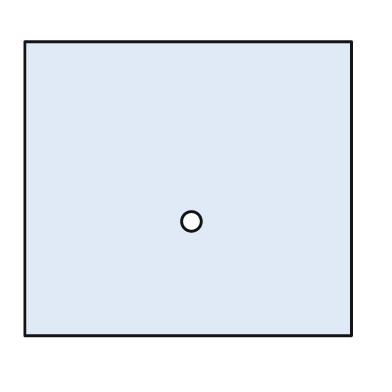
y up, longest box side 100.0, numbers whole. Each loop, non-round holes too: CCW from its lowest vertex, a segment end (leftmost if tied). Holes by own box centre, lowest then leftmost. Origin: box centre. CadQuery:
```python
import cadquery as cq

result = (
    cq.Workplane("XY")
    .moveTo(-50.0, -45.0)
    .lineTo(50.0, -45.0)
    .lineTo(50.0, 45.0)
    .lineTo(-50.0, 45.0)
    .close()
    .moveTo(1.0, -10.0)
    .circle(3.0)
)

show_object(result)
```